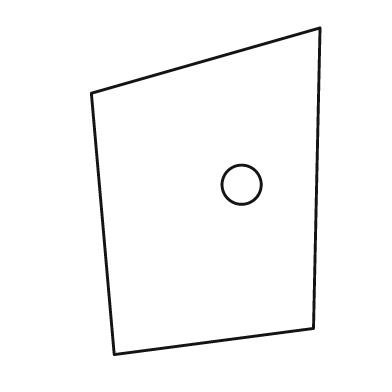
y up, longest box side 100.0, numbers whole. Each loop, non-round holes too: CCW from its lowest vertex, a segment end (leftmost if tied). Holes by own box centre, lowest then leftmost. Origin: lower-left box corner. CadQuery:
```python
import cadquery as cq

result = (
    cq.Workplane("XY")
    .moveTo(7.0, 0.0)
    .lineTo(68.0, 8.0)
    .lineTo(70.0, 100.0)
    .lineTo(0.0, 80.0)
    .close()
    .moveTo(46.0, 52.0)
    .circle(6.0)
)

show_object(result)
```